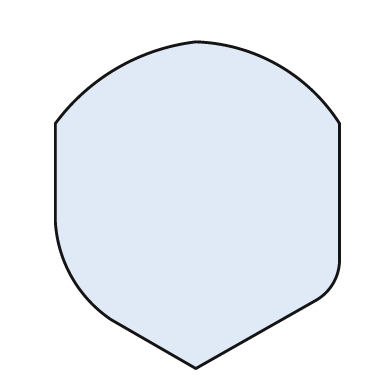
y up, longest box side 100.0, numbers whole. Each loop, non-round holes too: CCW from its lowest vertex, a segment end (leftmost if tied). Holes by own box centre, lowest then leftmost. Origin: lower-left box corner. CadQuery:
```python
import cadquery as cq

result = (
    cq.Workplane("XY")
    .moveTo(43.0, 0.0)
    .lineTo(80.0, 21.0)
    .threePointArc((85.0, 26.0), (87.0, 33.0))
    .lineTo(87.0, 75.0)
    .threePointArc((68.0, 93.0), (43.0, 100.0))
    .threePointArc((19.0, 92.0), (0.0, 75.0))
    .lineTo(0.0, 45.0)
    .threePointArc((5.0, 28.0), (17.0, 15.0))
    .close()
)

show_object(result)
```